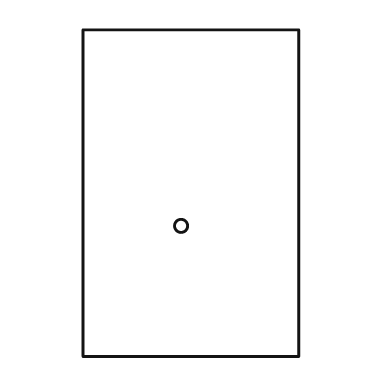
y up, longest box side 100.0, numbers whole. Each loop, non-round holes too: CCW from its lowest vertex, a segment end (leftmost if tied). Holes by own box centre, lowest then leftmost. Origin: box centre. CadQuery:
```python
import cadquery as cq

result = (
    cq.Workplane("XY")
    .moveTo(-33.0, -50.0)
    .lineTo(33.0, -50.0)
    .lineTo(33.0, 50.0)
    .lineTo(-33.0, 50.0)
    .close()
    .moveTo(-3.0, -10.0)
    .circle(2.0)
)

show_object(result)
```